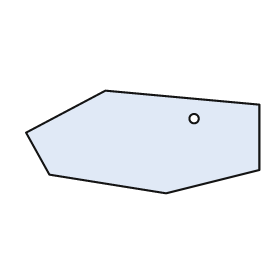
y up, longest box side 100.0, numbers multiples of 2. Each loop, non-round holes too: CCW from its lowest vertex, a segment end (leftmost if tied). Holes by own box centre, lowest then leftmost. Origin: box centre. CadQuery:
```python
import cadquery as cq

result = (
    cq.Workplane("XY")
    .moveTo(10.0, -22.0)
    .lineTo(50.0, -12.0)
    .lineTo(50.0, 16.0)
    .lineTo(-16.0, 22.0)
    .lineTo(-50.0, 4.0)
    .lineTo(-40.0, -14.0)
    .close()
    .moveTo(22.0, 10.0)
    .circle(2.0)
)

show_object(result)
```